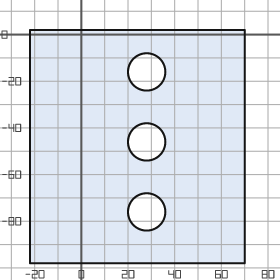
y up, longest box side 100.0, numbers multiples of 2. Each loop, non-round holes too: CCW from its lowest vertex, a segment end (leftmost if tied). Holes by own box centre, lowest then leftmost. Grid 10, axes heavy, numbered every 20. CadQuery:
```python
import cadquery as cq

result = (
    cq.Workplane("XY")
    .moveTo(-22.0, -98.0)
    .lineTo(70.0, -98.0)
    .lineTo(70.0, 2.0)
    .lineTo(-22.0, 2.0)
    .close()
    .moveTo(28.0, -76.0)
    .circle(8.0)
    .moveTo(28.0, -46.0)
    .circle(8.0)
    .moveTo(28.0, -16.0)
    .circle(8.0)
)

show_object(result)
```